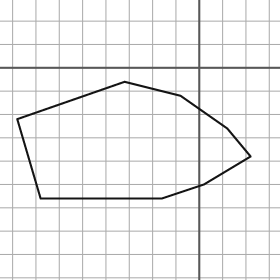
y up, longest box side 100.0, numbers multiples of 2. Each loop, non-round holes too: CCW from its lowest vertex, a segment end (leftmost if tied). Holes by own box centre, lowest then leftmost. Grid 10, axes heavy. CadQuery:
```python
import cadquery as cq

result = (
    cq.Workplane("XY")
    .moveTo(-68.0, -56.0)
    .lineTo(-16.0, -56.0)
    .lineTo(2.0, -50.0)
    .lineTo(22.0, -38.0)
    .lineTo(12.0, -26.0)
    .lineTo(-8.0, -12.0)
    .lineTo(-32.0, -6.0)
    .lineTo(-78.0, -22.0)
    .close()
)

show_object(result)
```